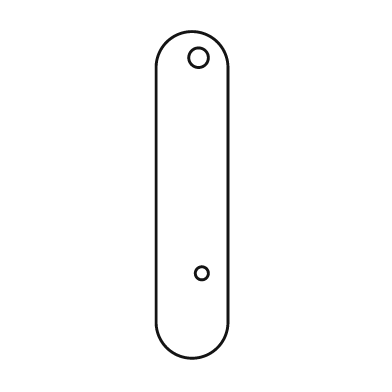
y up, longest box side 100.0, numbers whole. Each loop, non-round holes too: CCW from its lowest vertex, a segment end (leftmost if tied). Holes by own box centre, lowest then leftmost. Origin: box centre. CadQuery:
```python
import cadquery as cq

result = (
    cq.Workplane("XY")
    .moveTo(-11.0, -39.0)
    .threePointArc((0.0, -50.0), (11.0, -39.0))
    .lineTo(11.0, 39.0)
    .threePointArc((0.0, 50.0), (-11.0, 39.0))
    .close()
    .moveTo(3.0, -24.0)
    .circle(2.0)
    .moveTo(2.0, 42.0)
    .circle(3.0)
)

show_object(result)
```